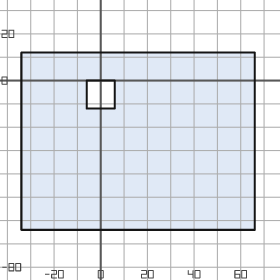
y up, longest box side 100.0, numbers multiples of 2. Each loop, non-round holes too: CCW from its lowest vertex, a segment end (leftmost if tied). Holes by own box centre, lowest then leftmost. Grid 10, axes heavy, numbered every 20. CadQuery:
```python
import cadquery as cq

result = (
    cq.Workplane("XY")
    .moveTo(-34.0, -64.0)
    .lineTo(66.0, -64.0)
    .lineTo(66.0, 12.0)
    .lineTo(-34.0, 12.0)
    .close()
    .moveTo(-6.0, -12.0)
    .lineTo(6.0, -12.0)
    .lineTo(6.0, 0.0)
    .lineTo(-6.0, 0.0)
    .close()
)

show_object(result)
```